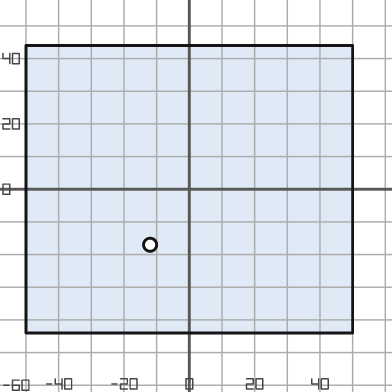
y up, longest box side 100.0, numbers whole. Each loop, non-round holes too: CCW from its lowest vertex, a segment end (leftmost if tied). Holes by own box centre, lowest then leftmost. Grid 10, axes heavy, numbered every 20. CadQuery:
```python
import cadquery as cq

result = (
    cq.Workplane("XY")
    .moveTo(-50.0, -44.0)
    .lineTo(50.0, -44.0)
    .lineTo(50.0, 44.0)
    .lineTo(-50.0, 44.0)
    .close()
    .moveTo(-12.0, -17.0)
    .circle(2.0)
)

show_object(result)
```